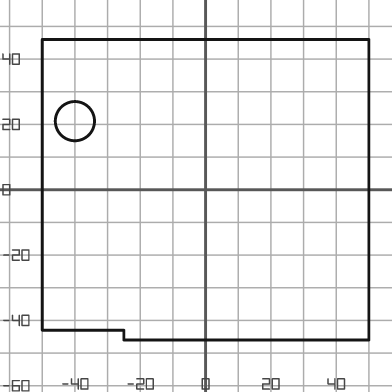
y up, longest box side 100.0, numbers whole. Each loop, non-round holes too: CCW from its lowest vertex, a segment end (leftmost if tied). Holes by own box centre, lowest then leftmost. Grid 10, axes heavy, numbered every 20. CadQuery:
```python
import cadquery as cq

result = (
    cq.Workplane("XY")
    .moveTo(-25.0, -46.0)
    .lineTo(50.0, -46.0)
    .lineTo(50.0, 46.0)
    .lineTo(-50.0, 46.0)
    .lineTo(-50.0, -43.0)
    .lineTo(-25.0, -43.0)
    .close()
    .moveTo(-40.0, 21.0)
    .circle(6.0)
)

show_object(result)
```